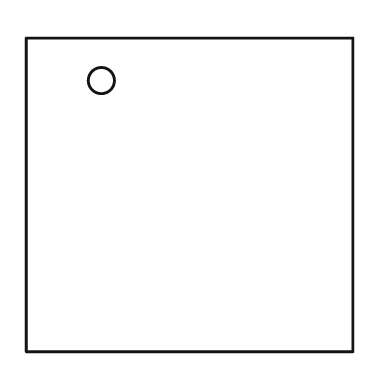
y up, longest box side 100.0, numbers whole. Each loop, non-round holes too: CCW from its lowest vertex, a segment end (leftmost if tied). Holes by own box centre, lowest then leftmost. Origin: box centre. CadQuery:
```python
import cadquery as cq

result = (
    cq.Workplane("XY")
    .moveTo(-50.0, -48.0)
    .lineTo(50.0, -48.0)
    .lineTo(50.0, 48.0)
    .lineTo(-50.0, 48.0)
    .close()
    .moveTo(-27.0, 35.0)
    .circle(4.0)
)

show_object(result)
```